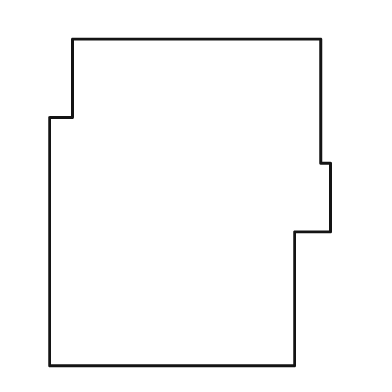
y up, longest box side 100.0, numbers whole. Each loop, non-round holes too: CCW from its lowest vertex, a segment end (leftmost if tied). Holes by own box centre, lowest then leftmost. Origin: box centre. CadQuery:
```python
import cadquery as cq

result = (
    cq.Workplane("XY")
    .moveTo(-43.0, -50.0)
    .lineTo(32.0, -50.0)
    .lineTo(32.0, -9.0)
    .lineTo(43.0, -9.0)
    .lineTo(43.0, 12.0)
    .lineTo(40.0, 12.0)
    .lineTo(40.0, 50.0)
    .lineTo(-36.0, 50.0)
    .lineTo(-36.0, 26.0)
    .lineTo(-43.0, 26.0)
    .close()
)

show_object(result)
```